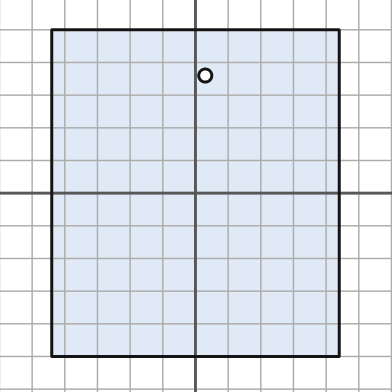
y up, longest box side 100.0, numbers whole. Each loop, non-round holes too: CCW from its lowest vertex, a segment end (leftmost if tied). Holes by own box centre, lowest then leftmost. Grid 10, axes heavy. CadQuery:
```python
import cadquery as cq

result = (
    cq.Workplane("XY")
    .moveTo(-44.0, -50.0)
    .lineTo(44.0, -50.0)
    .lineTo(44.0, 50.0)
    .lineTo(-44.0, 50.0)
    .close()
    .moveTo(3.0, 36.0)
    .circle(2.0)
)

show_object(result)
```